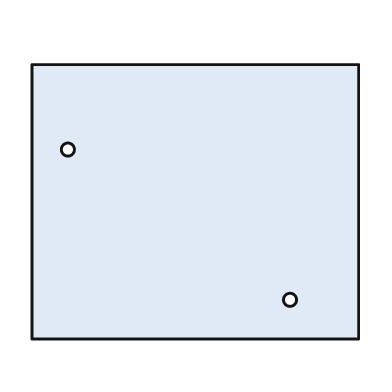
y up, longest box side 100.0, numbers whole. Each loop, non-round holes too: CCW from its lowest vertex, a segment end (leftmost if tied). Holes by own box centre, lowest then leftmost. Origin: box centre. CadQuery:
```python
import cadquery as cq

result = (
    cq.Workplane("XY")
    .moveTo(-50.0, -42.0)
    .lineTo(50.0, -42.0)
    .lineTo(50.0, 42.0)
    .lineTo(-50.0, 42.0)
    .close()
    .moveTo(29.0, -30.0)
    .circle(2.0)
    .moveTo(-39.0, 16.0)
    .circle(2.0)
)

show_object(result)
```